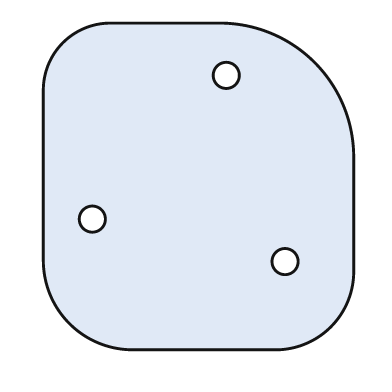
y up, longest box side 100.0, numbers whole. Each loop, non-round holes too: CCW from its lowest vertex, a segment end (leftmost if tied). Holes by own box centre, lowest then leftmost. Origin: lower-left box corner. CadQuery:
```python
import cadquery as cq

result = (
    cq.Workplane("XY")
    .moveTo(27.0, 0.0)
    .lineTo(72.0, 0.0)
    .threePointArc((88.0, 7.0), (95.0, 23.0))
    .lineTo(95.0, 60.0)
    .threePointArc((83.0, 88.0), (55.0, 100.0))
    .lineTo(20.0, 100.0)
    .threePointArc((6.0, 94.0), (0.0, 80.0))
    .lineTo(0.0, 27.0)
    .threePointArc((8.0, 8.0), (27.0, 0.0))
    .close()
    .moveTo(74.0, 27.0)
    .circle(4.0)
    .moveTo(15.0, 40.0)
    .circle(4.0)
    .moveTo(56.0, 84.0)
    .circle(4.0)
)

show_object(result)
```